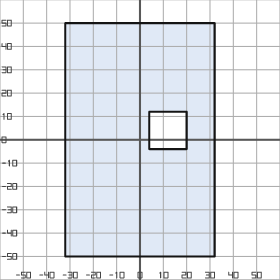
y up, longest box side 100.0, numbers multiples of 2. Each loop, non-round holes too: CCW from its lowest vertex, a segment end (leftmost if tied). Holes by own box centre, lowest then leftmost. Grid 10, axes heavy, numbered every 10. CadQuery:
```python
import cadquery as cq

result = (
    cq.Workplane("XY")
    .moveTo(-32.0, -50.0)
    .lineTo(32.0, -50.0)
    .lineTo(32.0, 50.0)
    .lineTo(-32.0, 50.0)
    .close()
    .moveTo(4.0, -4.0)
    .lineTo(20.0, -4.0)
    .lineTo(20.0, 12.0)
    .lineTo(4.0, 12.0)
    .close()
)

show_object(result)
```